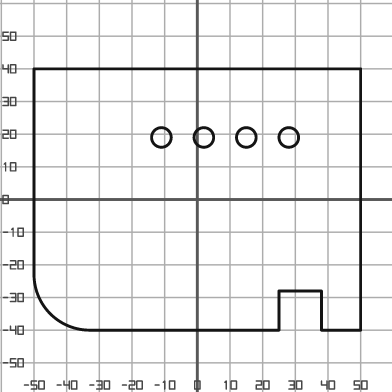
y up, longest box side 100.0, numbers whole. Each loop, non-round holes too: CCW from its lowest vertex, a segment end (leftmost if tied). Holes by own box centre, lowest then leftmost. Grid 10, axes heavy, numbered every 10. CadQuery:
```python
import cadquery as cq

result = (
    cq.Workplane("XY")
    .moveTo(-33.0, -40.0)
    .lineTo(25.0, -40.0)
    .lineTo(25.0, -28.0)
    .lineTo(38.0, -28.0)
    .lineTo(38.0, -40.0)
    .lineTo(50.0, -40.0)
    .lineTo(50.0, 40.0)
    .lineTo(-50.0, 40.0)
    .lineTo(-50.0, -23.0)
    .threePointArc((-45.0, -35.0), (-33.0, -40.0))
    .close()
    .moveTo(-11.0, 19.0)
    .circle(3.0)
    .moveTo(2.0, 19.0)
    .circle(3.0)
    .moveTo(15.0, 19.0)
    .circle(3.0)
    .moveTo(28.0, 19.0)
    .circle(3.0)
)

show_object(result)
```